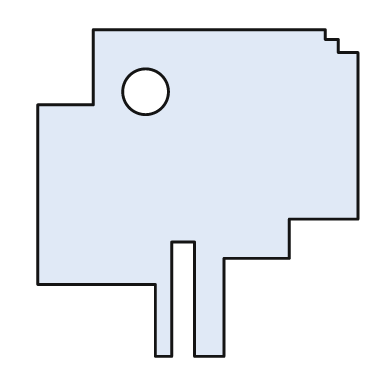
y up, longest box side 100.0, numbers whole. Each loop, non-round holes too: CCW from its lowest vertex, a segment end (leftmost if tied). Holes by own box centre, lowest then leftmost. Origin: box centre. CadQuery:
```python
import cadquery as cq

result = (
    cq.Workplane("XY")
    .moveTo(-13.0, -50.0)
    .lineTo(-8.0, -50.0)
    .lineTo(-8.0, -15.0)
    .lineTo(-1.0, -15.0)
    .lineTo(-1.0, -50.0)
    .lineTo(8.0, -50.0)
    .lineTo(8.0, -20.0)
    .lineTo(28.0, -20.0)
    .lineTo(28.0, -8.0)
    .lineTo(49.0, -8.0)
    .lineTo(49.0, 43.0)
    .lineTo(43.0, 43.0)
    .lineTo(43.0, 47.0)
    .lineTo(39.0, 47.0)
    .lineTo(39.0, 50.0)
    .lineTo(-32.0, 50.0)
    .lineTo(-32.0, 27.0)
    .lineTo(-49.0, 27.0)
    .lineTo(-49.0, -28.0)
    .lineTo(-13.0, -28.0)
    .close()
    .moveTo(-16.0, 31.0)
    .circle(7.0)
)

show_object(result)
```